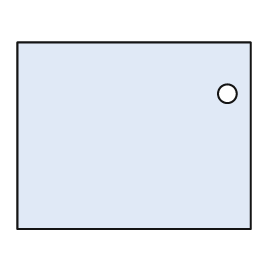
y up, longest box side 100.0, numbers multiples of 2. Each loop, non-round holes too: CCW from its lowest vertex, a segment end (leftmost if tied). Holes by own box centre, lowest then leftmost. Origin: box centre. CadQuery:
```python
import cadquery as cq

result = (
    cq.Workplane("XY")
    .moveTo(-50.0, -40.0)
    .lineTo(50.0, -40.0)
    .lineTo(50.0, 40.0)
    .lineTo(-50.0, 40.0)
    .close()
    .moveTo(40.0, 18.0)
    .circle(4.0)
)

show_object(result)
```